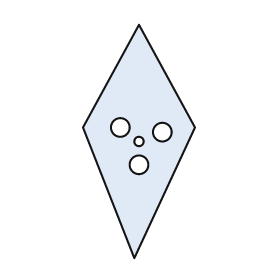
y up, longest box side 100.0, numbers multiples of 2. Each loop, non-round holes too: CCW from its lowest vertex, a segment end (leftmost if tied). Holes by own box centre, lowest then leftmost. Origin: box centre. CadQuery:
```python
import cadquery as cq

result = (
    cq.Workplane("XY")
    .moveTo(-2.0, -50.0)
    .lineTo(24.0, 6.0)
    .lineTo(0.0, 50.0)
    .lineTo(-24.0, 6.0)
    .close()
    .moveTo(0.0, -10.0)
    .circle(4.0)
    .moveTo(0.0, 0.0)
    .circle(2.0)
    .moveTo(10.0, 4.0)
    .circle(4.0)
    .moveTo(-8.0, 6.0)
    .circle(4.0)
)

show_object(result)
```